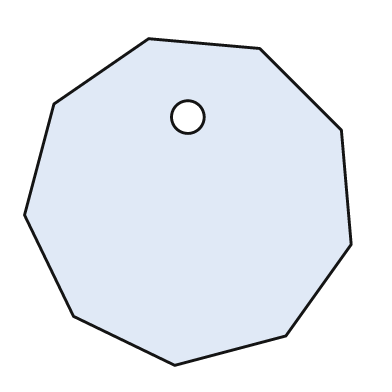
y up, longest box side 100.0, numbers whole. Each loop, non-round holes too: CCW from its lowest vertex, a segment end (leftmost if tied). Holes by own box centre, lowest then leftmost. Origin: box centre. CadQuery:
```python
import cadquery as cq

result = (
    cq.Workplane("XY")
    .moveTo(-4.0, -50.0)
    .lineTo(30.0, -41.0)
    .lineTo(50.0, -13.0)
    .lineTo(47.0, 22.0)
    .lineTo(22.0, 47.0)
    .lineTo(-12.0, 50.0)
    .lineTo(-41.0, 30.0)
    .lineTo(-50.0, -4.0)
    .lineTo(-35.0, -35.0)
    .close()
    .moveTo(0.0, 26.0)
    .circle(5.0)
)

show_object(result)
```